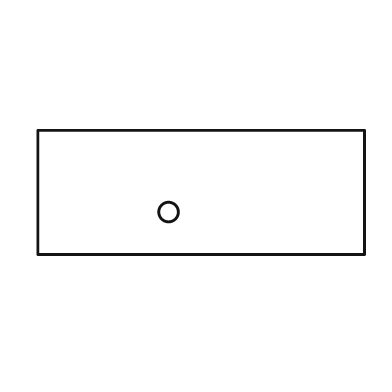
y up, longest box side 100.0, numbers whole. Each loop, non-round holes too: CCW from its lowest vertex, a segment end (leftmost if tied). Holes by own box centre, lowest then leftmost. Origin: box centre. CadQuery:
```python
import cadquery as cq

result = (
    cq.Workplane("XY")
    .moveTo(-50.0, -19.0)
    .lineTo(50.0, -19.0)
    .lineTo(50.0, 19.0)
    .lineTo(-50.0, 19.0)
    .close()
    .moveTo(-10.0, -6.0)
    .circle(3.0)
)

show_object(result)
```